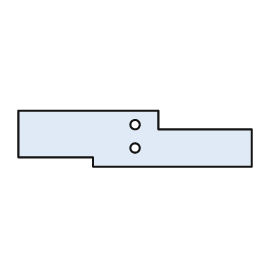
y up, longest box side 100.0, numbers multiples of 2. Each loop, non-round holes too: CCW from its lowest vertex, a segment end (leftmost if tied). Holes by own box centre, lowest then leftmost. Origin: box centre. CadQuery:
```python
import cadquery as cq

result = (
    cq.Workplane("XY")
    .moveTo(-18.0, -12.0)
    .lineTo(50.0, -12.0)
    .lineTo(50.0, 4.0)
    .lineTo(10.0, 4.0)
    .lineTo(10.0, 12.0)
    .lineTo(-50.0, 12.0)
    .lineTo(-50.0, -8.0)
    .lineTo(-18.0, -8.0)
    .close()
    .moveTo(0.0, -4.0)
    .circle(2.0)
    .moveTo(0.0, 6.0)
    .circle(2.0)
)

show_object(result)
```